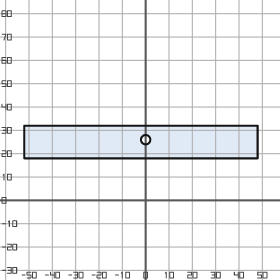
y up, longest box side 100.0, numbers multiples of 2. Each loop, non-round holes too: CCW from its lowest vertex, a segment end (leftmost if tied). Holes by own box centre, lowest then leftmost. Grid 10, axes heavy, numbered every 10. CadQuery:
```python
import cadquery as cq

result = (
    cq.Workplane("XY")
    .moveTo(-52.0, 18.0)
    .lineTo(48.0, 18.0)
    .lineTo(48.0, 32.0)
    .lineTo(-52.0, 32.0)
    .close()
    .moveTo(0.0, 26.0)
    .circle(2.0)
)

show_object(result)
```